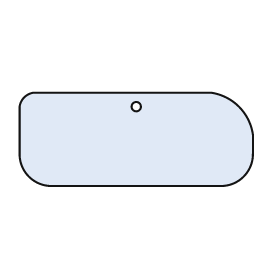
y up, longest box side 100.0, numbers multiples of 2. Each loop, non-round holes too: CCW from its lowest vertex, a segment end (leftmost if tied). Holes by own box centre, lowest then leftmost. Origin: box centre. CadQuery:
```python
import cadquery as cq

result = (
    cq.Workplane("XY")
    .moveTo(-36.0, -20.0)
    .lineTo(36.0, -20.0)
    .threePointArc((46.0, -16.0), (50.0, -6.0))
    .lineTo(50.0, 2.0)
    .threePointArc((44.0, 14.0), (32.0, 20.0))
    .lineTo(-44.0, 20.0)
    .threePointArc((-48.0, 18.0), (-50.0, 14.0))
    .lineTo(-50.0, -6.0)
    .threePointArc((-46.0, -16.0), (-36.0, -20.0))
    .close()
    .moveTo(0.0, 14.0)
    .circle(2.0)
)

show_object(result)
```